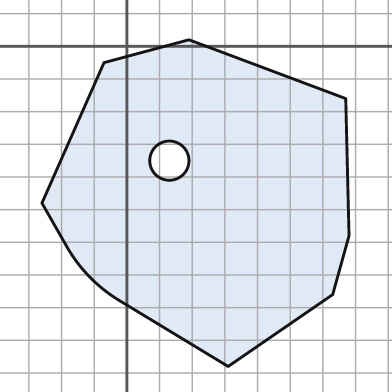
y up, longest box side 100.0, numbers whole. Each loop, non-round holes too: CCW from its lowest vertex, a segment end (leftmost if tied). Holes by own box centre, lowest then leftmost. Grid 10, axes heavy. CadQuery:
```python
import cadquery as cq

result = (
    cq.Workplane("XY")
    .moveTo(31.0, -98.0)
    .lineTo(63.0, -76.0)
    .lineTo(68.0, -58.0)
    .lineTo(67.0, -16.0)
    .lineTo(19.0, 2.0)
    .lineTo(-7.0, -5.0)
    .lineTo(-26.0, -48.0)
    .lineTo(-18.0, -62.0)
    .threePointArc((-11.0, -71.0), (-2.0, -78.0))
    .close()
    .moveTo(13.0, -35.0)
    .circle(6.0)
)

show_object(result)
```